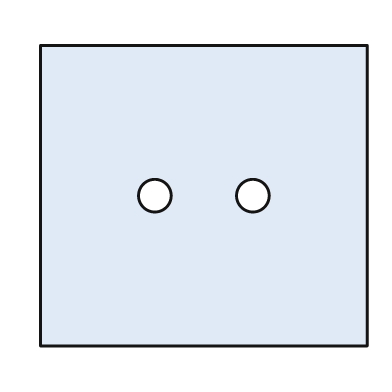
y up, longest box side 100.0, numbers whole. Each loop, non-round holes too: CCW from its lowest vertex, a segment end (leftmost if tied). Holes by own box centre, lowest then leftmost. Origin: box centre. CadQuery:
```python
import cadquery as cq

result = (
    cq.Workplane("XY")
    .moveTo(-50.0, -46.0)
    .lineTo(50.0, -46.0)
    .lineTo(50.0, 46.0)
    .lineTo(-50.0, 46.0)
    .close()
    .moveTo(-15.0, 0.0)
    .circle(5.0)
    .moveTo(15.0, 0.0)
    .circle(5.0)
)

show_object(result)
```